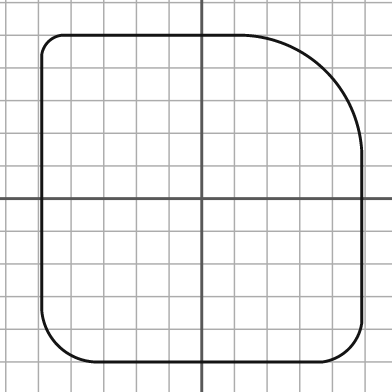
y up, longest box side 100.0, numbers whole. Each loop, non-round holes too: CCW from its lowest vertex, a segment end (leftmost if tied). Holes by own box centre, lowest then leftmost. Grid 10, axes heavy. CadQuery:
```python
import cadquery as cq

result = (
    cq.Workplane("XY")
    .moveTo(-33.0, -50.0)
    .lineTo(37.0, -50.0)
    .threePointArc((45.0, -46.0), (49.0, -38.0))
    .lineTo(49.0, 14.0)
    .threePointArc((38.0, 39.0), (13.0, 50.0))
    .lineTo(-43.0, 50.0)
    .threePointArc((-47.0, 48.0), (-49.0, 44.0))
    .lineTo(-49.0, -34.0)
    .threePointArc((-44.0, -45.0), (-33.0, -50.0))
    .close()
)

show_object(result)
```